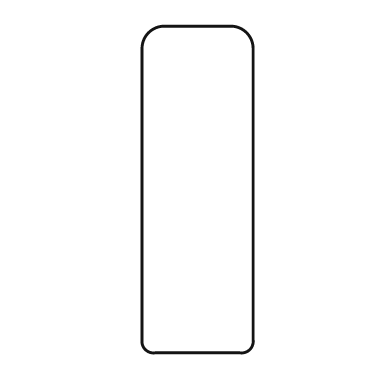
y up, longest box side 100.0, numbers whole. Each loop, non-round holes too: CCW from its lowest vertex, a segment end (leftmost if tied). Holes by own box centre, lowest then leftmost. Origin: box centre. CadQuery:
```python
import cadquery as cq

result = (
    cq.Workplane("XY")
    .moveTo(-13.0, -50.0)
    .lineTo(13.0, -50.0)
    .threePointArc((16.0, -49.0), (17.0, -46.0))
    .lineTo(17.0, 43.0)
    .threePointArc((15.0, 48.0), (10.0, 50.0))
    .lineTo(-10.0, 50.0)
    .threePointArc((-15.0, 48.0), (-17.0, 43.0))
    .lineTo(-17.0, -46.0)
    .threePointArc((-16.0, -49.0), (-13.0, -50.0))
    .close()
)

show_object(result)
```